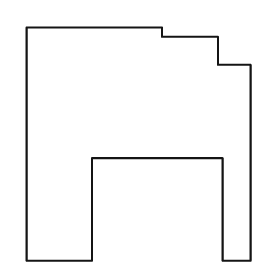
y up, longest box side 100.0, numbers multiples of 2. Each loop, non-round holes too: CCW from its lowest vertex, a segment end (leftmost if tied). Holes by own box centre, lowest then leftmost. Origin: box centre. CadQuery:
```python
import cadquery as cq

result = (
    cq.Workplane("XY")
    .moveTo(-48.0, -50.0)
    .lineTo(-20.0, -50.0)
    .lineTo(-20.0, -6.0)
    .lineTo(36.0, -6.0)
    .lineTo(36.0, -50.0)
    .lineTo(48.0, -50.0)
    .lineTo(48.0, 34.0)
    .lineTo(34.0, 34.0)
    .lineTo(34.0, 46.0)
    .lineTo(10.0, 46.0)
    .lineTo(10.0, 50.0)
    .lineTo(-48.0, 50.0)
    .close()
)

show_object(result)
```